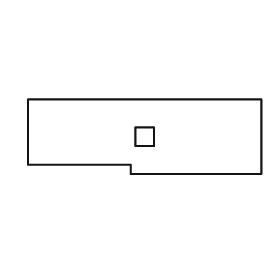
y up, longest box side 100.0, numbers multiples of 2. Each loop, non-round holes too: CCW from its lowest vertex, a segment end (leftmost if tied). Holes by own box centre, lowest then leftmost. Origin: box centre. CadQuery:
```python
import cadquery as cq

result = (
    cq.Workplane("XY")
    .moveTo(-6.0, -16.0)
    .lineTo(50.0, -16.0)
    .lineTo(50.0, 16.0)
    .lineTo(-50.0, 16.0)
    .lineTo(-50.0, -12.0)
    .lineTo(-6.0, -12.0)
    .close()
    .moveTo(-4.0, -4.0)
    .lineTo(4.0, -4.0)
    .lineTo(4.0, 4.0)
    .lineTo(-4.0, 4.0)
    .close()
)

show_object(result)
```